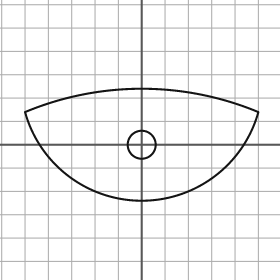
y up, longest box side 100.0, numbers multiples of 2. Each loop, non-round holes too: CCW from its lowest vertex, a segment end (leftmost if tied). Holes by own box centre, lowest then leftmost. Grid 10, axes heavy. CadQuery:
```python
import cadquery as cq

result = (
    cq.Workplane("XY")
    .moveTo(-50.0, 14.0)
    .threePointArc((0.0, -24.0), (50.0, 14.0))
    .threePointArc((0.0, 24.0), (-50.0, 14.0))
    .close()
    .moveTo(0.0, 0.0)
    .circle(6.0)
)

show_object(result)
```